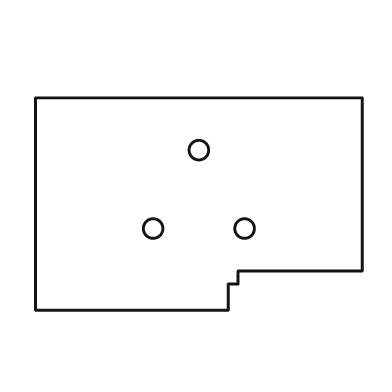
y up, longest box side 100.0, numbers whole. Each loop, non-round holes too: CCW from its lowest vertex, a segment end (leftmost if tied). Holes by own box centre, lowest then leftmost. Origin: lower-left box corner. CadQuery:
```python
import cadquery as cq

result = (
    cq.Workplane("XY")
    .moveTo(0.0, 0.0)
    .lineTo(59.0, 0.0)
    .lineTo(59.0, 8.0)
    .lineTo(62.0, 8.0)
    .lineTo(62.0, 12.0)
    .lineTo(100.0, 12.0)
    .lineTo(100.0, 65.0)
    .lineTo(0.0, 65.0)
    .close()
    .moveTo(36.0, 25.0)
    .circle(3.0)
    .moveTo(64.0, 25.0)
    .circle(3.0)
    .moveTo(50.0, 49.0)
    .circle(3.0)
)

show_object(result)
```